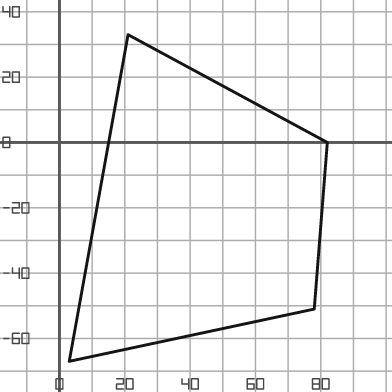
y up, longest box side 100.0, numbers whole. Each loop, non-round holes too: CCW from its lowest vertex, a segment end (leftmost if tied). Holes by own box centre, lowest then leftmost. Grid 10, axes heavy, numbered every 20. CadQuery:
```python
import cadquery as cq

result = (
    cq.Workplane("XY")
    .moveTo(3.0, -67.0)
    .lineTo(78.0, -51.0)
    .lineTo(82.0, 0.0)
    .lineTo(21.0, 33.0)
    .close()
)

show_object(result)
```